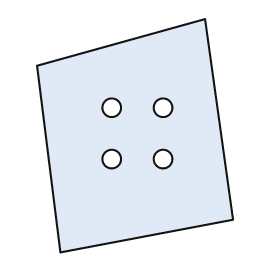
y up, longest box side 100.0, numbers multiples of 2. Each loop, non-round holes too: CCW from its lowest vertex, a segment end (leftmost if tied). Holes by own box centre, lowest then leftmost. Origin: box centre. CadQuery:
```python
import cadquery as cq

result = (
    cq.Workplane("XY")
    .moveTo(-32.0, -50.0)
    .lineTo(42.0, -36.0)
    .lineTo(30.0, 50.0)
    .lineTo(-42.0, 30.0)
    .close()
    .moveTo(-10.0, -10.0)
    .circle(4.0)
    .moveTo(12.0, -10.0)
    .circle(4.0)
    .moveTo(-10.0, 12.0)
    .circle(4.0)
    .moveTo(12.0, 12.0)
    .circle(4.0)
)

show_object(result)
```